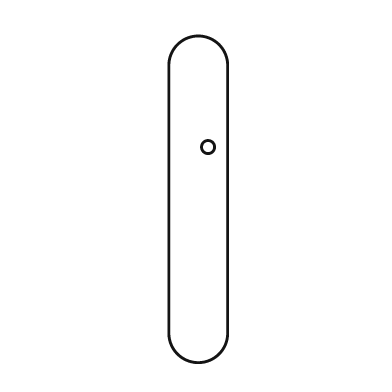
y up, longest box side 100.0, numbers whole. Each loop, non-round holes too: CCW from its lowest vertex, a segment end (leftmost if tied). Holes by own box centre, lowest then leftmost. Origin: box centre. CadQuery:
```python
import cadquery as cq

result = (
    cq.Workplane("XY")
    .moveTo(-9.0, -41.0)
    .threePointArc((0.0, -50.0), (9.0, -41.0))
    .lineTo(9.0, 41.0)
    .threePointArc((0.0, 50.0), (-9.0, 41.0))
    .close()
    .moveTo(3.0, 16.0)
    .circle(2.0)
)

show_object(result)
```